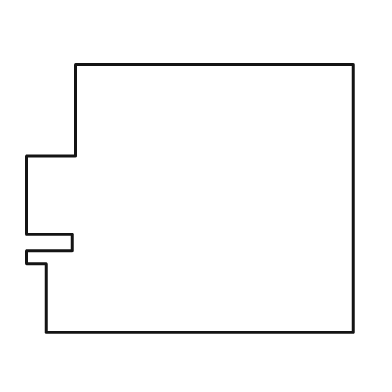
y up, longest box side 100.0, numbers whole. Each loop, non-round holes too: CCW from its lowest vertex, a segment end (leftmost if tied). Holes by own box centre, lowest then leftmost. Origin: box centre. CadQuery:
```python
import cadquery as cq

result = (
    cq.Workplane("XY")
    .moveTo(-44.0, -41.0)
    .lineTo(50.0, -41.0)
    .lineTo(50.0, 41.0)
    .lineTo(-35.0, 41.0)
    .lineTo(-35.0, 13.0)
    .lineTo(-50.0, 13.0)
    .lineTo(-50.0, -11.0)
    .lineTo(-36.0, -11.0)
    .lineTo(-36.0, -16.0)
    .lineTo(-50.0, -16.0)
    .lineTo(-50.0, -20.0)
    .lineTo(-44.0, -20.0)
    .close()
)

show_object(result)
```